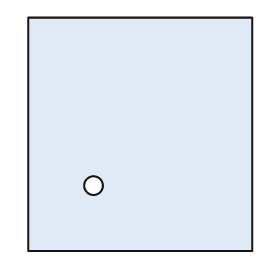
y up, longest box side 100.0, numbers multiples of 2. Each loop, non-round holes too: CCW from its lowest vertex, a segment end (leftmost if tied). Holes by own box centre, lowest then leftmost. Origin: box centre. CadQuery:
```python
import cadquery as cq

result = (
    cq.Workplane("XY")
    .moveTo(-48.0, -50.0)
    .lineTo(48.0, -50.0)
    .lineTo(48.0, 50.0)
    .lineTo(-48.0, 50.0)
    .close()
    .moveTo(-20.0, -22.0)
    .circle(4.0)
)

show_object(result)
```